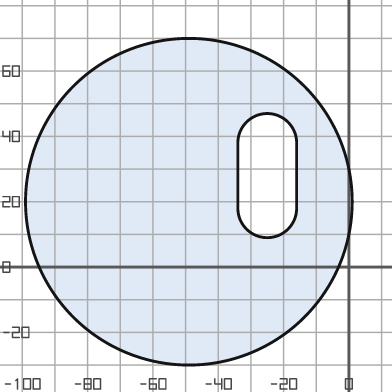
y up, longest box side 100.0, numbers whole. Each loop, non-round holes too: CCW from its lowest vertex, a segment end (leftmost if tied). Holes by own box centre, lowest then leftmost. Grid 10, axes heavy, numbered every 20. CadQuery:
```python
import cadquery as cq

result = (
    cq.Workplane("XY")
    .moveTo(-49.0, 20.0)
    .circle(50.0)
    .moveTo(-34.0, 18.0)
    .threePointArc((-25.0, 9.0), (-16.0, 18.0))
    .lineTo(-16.0, 38.0)
    .threePointArc((-25.0, 47.0), (-34.0, 38.0))
    .close()
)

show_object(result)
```